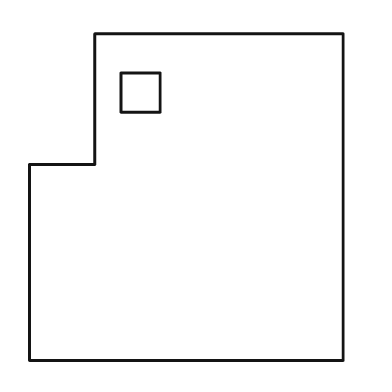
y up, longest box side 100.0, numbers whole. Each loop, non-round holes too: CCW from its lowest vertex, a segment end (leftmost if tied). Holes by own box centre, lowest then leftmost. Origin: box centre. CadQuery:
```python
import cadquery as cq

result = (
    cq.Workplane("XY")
    .moveTo(-48.0, -50.0)
    .lineTo(48.0, -50.0)
    .lineTo(48.0, 50.0)
    .lineTo(-28.0, 50.0)
    .lineTo(-28.0, 10.0)
    .lineTo(-48.0, 10.0)
    .close()
    .moveTo(-20.0, 26.0)
    .lineTo(-8.0, 26.0)
    .lineTo(-8.0, 38.0)
    .lineTo(-20.0, 38.0)
    .close()
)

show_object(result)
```